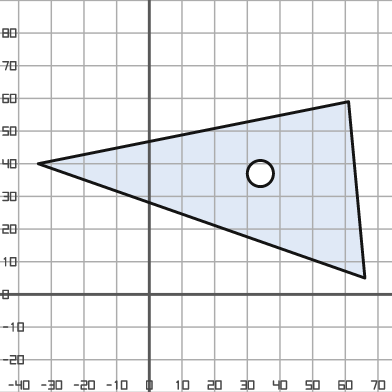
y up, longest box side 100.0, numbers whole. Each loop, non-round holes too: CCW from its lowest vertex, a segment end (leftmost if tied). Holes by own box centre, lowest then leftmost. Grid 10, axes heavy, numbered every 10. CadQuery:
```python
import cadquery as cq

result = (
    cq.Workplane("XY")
    .moveTo(66.0, 5.0)
    .lineTo(61.0, 59.0)
    .lineTo(-34.0, 40.0)
    .close()
    .moveTo(34.0, 37.0)
    .circle(4.0)
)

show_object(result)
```